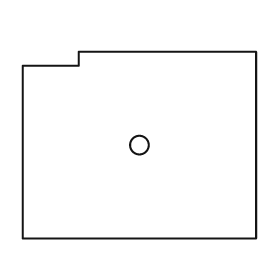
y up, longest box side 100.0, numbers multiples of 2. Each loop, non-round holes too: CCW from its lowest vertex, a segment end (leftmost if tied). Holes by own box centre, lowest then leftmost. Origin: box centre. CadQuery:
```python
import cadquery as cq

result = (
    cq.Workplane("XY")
    .moveTo(-50.0, -40.0)
    .lineTo(50.0, -40.0)
    .lineTo(50.0, 40.0)
    .lineTo(-26.0, 40.0)
    .lineTo(-26.0, 34.0)
    .lineTo(-50.0, 34.0)
    .close()
    .moveTo(0.0, 0.0)
    .circle(4.0)
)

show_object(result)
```